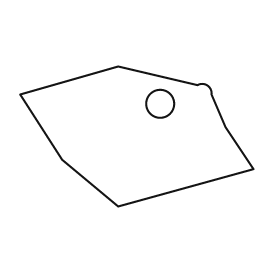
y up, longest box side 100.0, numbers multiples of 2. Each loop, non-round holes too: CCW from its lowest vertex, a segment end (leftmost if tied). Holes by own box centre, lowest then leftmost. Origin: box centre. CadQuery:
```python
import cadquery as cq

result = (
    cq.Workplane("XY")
    .moveTo(-8.0, -30.0)
    .lineTo(50.0, -14.0)
    .lineTo(38.0, 4.0)
    .lineTo(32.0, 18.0)
    .threePointArc((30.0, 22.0), (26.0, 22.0))
    .lineTo(-8.0, 30.0)
    .lineTo(-50.0, 18.0)
    .lineTo(-32.0, -10.0)
    .close()
    .moveTo(10.0, 14.0)
    .circle(6.0)
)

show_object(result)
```